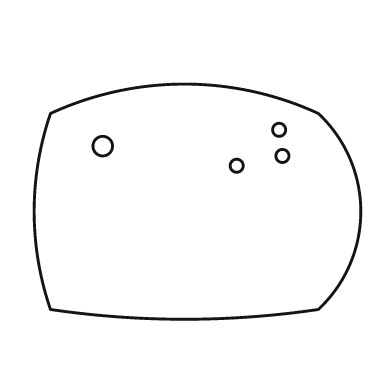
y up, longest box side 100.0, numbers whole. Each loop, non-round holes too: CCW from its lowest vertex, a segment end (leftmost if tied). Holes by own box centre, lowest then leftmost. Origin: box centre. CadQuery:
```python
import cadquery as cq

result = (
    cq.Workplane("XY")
    .moveTo(-45.0, -33.0)
    .threePointArc((-4.0, -36.0), (37.0, -33.0))
    .threePointArc((50.0, -3.0), (37.0, 27.0))
    .threePointArc((-4.0, 36.0), (-45.0, 27.0))
    .threePointArc((-50.0, -3.0), (-45.0, -33.0))
    .close()
    .moveTo(12.0, 11.0)
    .circle(2.0)
    .moveTo(26.0, 14.0)
    .circle(2.0)
    .moveTo(-29.0, 17.0)
    .circle(3.0)
    .moveTo(25.0, 22.0)
    .circle(2.0)
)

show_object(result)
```